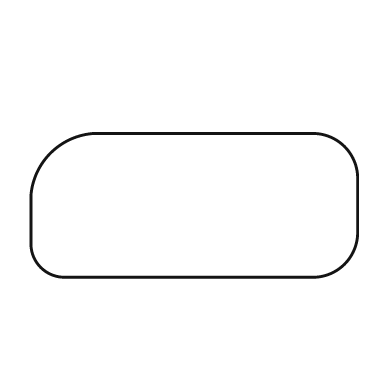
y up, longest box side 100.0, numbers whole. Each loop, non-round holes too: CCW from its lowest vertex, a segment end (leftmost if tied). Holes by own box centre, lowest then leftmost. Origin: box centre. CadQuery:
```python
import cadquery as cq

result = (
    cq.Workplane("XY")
    .moveTo(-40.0, -22.0)
    .lineTo(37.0, -22.0)
    .threePointArc((46.0, -18.0), (50.0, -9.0))
    .lineTo(50.0, 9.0)
    .threePointArc((46.0, 18.0), (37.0, 22.0))
    .lineTo(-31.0, 22.0)
    .threePointArc((-44.0, 16.0), (-50.0, 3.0))
    .lineTo(-50.0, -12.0)
    .threePointArc((-47.0, -19.0), (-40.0, -22.0))
    .close()
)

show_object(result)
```